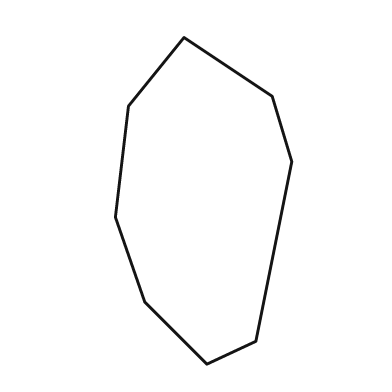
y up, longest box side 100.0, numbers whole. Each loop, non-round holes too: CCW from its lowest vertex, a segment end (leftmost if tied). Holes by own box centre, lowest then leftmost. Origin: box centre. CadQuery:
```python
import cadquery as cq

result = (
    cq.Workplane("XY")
    .moveTo(1.0, -50.0)
    .lineTo(16.0, -43.0)
    .lineTo(27.0, 12.0)
    .lineTo(21.0, 32.0)
    .lineTo(-6.0, 50.0)
    .lineTo(-23.0, 29.0)
    .lineTo(-27.0, -5.0)
    .lineTo(-18.0, -31.0)
    .close()
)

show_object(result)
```